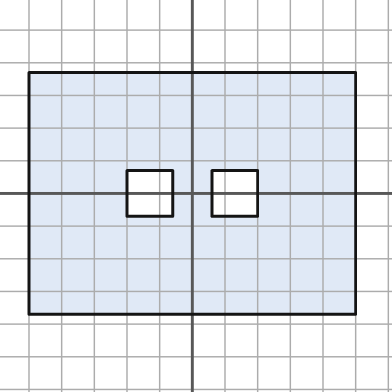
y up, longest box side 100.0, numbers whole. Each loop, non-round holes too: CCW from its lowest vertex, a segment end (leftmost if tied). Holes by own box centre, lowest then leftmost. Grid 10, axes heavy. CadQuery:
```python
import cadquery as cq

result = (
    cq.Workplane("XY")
    .moveTo(-50.0, -37.0)
    .lineTo(50.0, -37.0)
    .lineTo(50.0, 37.0)
    .lineTo(-50.0, 37.0)
    .close()
    .moveTo(-20.0, -7.0)
    .lineTo(-6.0, -7.0)
    .lineTo(-6.0, 7.0)
    .lineTo(-20.0, 7.0)
    .close()
    .moveTo(6.0, -7.0)
    .lineTo(20.0, -7.0)
    .lineTo(20.0, 7.0)
    .lineTo(6.0, 7.0)
    .close()
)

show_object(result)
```